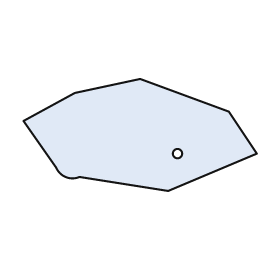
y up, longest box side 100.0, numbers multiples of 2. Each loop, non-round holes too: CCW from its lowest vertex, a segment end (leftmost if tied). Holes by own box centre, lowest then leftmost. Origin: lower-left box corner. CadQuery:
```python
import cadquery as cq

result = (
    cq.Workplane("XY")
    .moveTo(62.0, 0.0)
    .lineTo(100.0, 16.0)
    .lineTo(88.0, 34.0)
    .lineTo(50.0, 48.0)
    .lineTo(22.0, 42.0)
    .lineTo(0.0, 30.0)
    .lineTo(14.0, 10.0)
    .threePointArc((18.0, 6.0), (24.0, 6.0))
    .close()
    .moveTo(66.0, 16.0)
    .circle(2.0)
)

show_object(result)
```